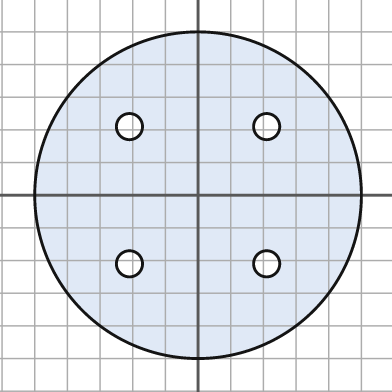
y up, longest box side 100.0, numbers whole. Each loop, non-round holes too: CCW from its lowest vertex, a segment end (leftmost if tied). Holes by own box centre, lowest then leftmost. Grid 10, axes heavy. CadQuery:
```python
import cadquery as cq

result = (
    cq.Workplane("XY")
    .moveTo(0.0, 0.0)
    .circle(50.0)
    .moveTo(-21.0, -21.0)
    .circle(4.0)
    .moveTo(21.0, -21.0)
    .circle(4.0)
    .moveTo(-21.0, 21.0)
    .circle(4.0)
    .moveTo(21.0, 21.0)
    .circle(4.0)
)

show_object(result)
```